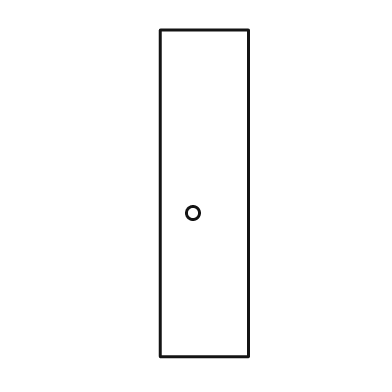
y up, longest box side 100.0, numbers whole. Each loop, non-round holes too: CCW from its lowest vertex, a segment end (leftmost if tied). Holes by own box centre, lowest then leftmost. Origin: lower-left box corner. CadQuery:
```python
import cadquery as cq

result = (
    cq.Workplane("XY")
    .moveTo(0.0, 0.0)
    .lineTo(27.0, 0.0)
    .lineTo(27.0, 100.0)
    .lineTo(0.0, 100.0)
    .close()
    .moveTo(10.0, 44.0)
    .circle(2.0)
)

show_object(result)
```